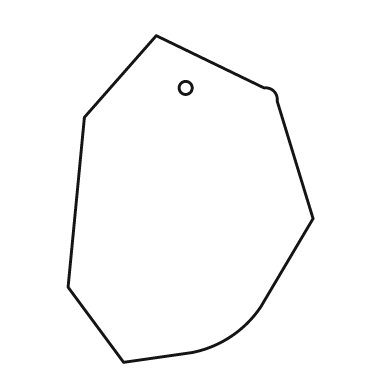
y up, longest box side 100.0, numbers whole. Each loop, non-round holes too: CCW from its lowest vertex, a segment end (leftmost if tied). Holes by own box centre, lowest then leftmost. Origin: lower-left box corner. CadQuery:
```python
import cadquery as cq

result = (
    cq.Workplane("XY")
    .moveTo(17.0, 0.0)
    .lineTo(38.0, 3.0)
    .threePointArc((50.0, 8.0), (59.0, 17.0))
    .lineTo(75.0, 44.0)
    .lineTo(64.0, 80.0)
    .threePointArc((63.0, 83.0), (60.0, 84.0))
    .lineTo(27.0, 100.0)
    .lineTo(5.0, 75.0)
    .lineTo(0.0, 23.0)
    .close()
    .moveTo(36.0, 84.0)
    .circle(2.0)
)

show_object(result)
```